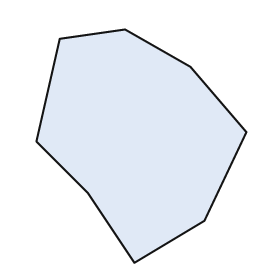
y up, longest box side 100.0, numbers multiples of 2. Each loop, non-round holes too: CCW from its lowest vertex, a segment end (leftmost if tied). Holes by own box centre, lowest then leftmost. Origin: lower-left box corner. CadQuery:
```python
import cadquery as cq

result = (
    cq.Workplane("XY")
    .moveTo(42.0, 0.0)
    .lineTo(72.0, 18.0)
    .lineTo(90.0, 56.0)
    .lineTo(66.0, 84.0)
    .lineTo(38.0, 100.0)
    .lineTo(10.0, 96.0)
    .lineTo(0.0, 52.0)
    .lineTo(22.0, 30.0)
    .close()
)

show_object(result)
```